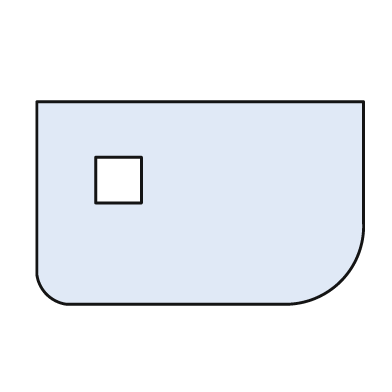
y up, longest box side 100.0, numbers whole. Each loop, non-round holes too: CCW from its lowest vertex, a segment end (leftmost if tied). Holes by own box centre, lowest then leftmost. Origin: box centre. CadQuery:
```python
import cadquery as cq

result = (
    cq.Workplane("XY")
    .moveTo(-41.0, -31.0)
    .lineTo(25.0, -31.0)
    .threePointArc((43.0, -24.0), (50.0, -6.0))
    .lineTo(50.0, 31.0)
    .lineTo(-50.0, 31.0)
    .lineTo(-50.0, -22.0)
    .threePointArc((-47.0, -28.0), (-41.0, -31.0))
    .close()
    .moveTo(-32.0, 0.0)
    .lineTo(-18.0, 0.0)
    .lineTo(-18.0, 14.0)
    .lineTo(-32.0, 14.0)
    .close()
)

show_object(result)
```